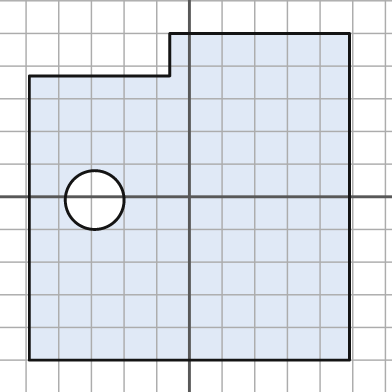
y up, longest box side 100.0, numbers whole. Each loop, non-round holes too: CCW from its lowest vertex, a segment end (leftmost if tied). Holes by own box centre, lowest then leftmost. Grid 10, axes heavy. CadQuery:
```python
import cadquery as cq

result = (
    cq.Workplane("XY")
    .moveTo(-49.0, -50.0)
    .lineTo(49.0, -50.0)
    .lineTo(49.0, 50.0)
    .lineTo(-6.0, 50.0)
    .lineTo(-6.0, 37.0)
    .lineTo(-49.0, 37.0)
    .close()
    .moveTo(-29.0, -1.0)
    .circle(9.0)
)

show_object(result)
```